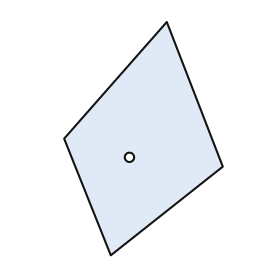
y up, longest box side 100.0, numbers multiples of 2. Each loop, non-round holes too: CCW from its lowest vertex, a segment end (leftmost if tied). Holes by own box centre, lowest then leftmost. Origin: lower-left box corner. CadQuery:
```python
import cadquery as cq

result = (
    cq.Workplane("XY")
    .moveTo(20.0, 0.0)
    .lineTo(68.0, 38.0)
    .lineTo(44.0, 100.0)
    .lineTo(0.0, 50.0)
    .close()
    .moveTo(28.0, 42.0)
    .circle(2.0)
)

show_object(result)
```